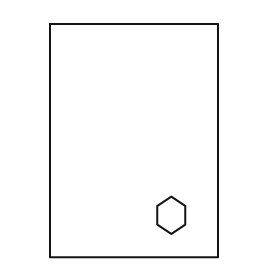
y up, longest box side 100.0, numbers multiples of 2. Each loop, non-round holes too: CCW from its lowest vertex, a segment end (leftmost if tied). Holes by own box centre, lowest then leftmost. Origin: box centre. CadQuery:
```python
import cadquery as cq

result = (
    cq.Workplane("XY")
    .moveTo(-36.0, -50.0)
    .lineTo(36.0, -50.0)
    .lineTo(36.0, 50.0)
    .lineTo(-36.0, 50.0)
    .close()
    .moveTo(16.0, -40.0)
    .lineTo(22.0, -36.0)
    .lineTo(22.0, -28.0)
    .lineTo(16.0, -24.0)
    .lineTo(10.0, -28.0)
    .lineTo(10.0, -36.0)
    .close()
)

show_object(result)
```